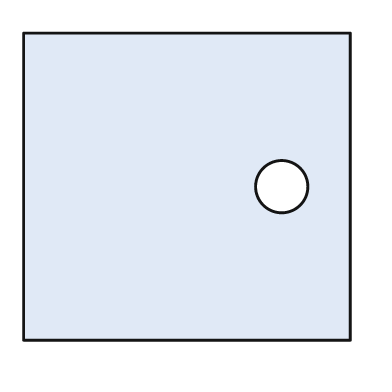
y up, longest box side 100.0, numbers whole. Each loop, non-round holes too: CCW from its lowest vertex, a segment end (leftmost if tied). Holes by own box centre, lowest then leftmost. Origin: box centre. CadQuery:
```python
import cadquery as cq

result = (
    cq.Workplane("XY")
    .moveTo(-50.0, -47.0)
    .lineTo(50.0, -47.0)
    .lineTo(50.0, 47.0)
    .lineTo(-50.0, 47.0)
    .close()
    .moveTo(29.0, 0.0)
    .circle(8.0)
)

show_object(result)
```